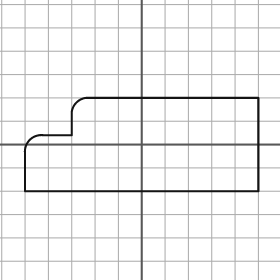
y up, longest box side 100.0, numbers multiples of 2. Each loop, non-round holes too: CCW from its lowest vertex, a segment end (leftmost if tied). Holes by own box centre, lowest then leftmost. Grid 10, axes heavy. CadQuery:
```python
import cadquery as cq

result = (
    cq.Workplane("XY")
    .moveTo(-50.0, -20.0)
    .lineTo(50.0, -20.0)
    .lineTo(50.0, 20.0)
    .lineTo(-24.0, 20.0)
    .threePointArc((-28.0, 18.0), (-30.0, 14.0))
    .lineTo(-30.0, 4.0)
    .lineTo(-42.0, 4.0)
    .threePointArc((-48.0, 2.0), (-50.0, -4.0))
    .close()
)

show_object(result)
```